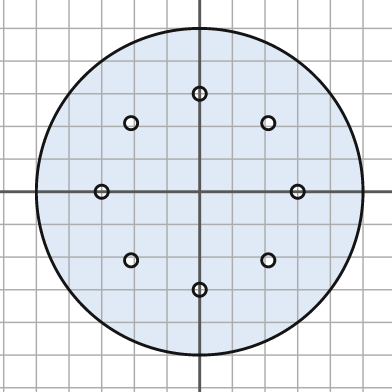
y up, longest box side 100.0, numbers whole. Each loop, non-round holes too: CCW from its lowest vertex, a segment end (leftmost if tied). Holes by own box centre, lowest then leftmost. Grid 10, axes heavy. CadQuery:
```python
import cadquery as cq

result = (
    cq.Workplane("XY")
    .moveTo(0.0, 0.0)
    .circle(50.0)
    .moveTo(0.0, -30.0)
    .circle(2.0)
    .moveTo(-21.0, -21.0)
    .circle(2.0)
    .moveTo(21.0, -21.0)
    .circle(2.0)
    .moveTo(-30.0, 0.0)
    .circle(2.0)
    .moveTo(30.0, 0.0)
    .circle(2.0)
    .moveTo(-21.0, 21.0)
    .circle(2.0)
    .moveTo(21.0, 21.0)
    .circle(2.0)
    .moveTo(0.0, 30.0)
    .circle(2.0)
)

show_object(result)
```